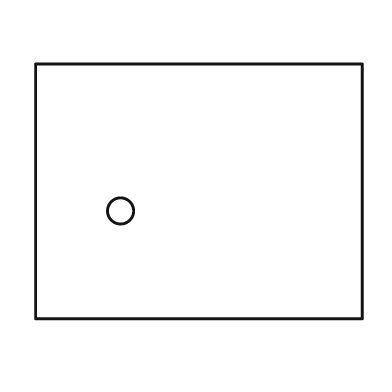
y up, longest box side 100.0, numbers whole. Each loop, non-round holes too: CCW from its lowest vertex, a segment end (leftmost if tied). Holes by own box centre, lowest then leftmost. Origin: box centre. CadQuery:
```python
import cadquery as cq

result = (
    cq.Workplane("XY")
    .moveTo(-50.0, -39.0)
    .lineTo(50.0, -39.0)
    .lineTo(50.0, 39.0)
    .lineTo(-50.0, 39.0)
    .close()
    .moveTo(-24.0, -6.0)
    .circle(4.0)
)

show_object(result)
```